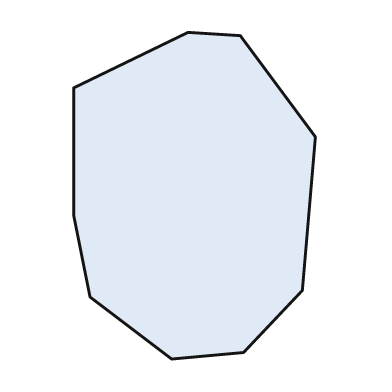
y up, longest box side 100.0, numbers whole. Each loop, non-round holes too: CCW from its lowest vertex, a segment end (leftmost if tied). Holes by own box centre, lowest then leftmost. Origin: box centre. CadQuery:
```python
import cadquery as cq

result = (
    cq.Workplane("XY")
    .moveTo(-7.0, -50.0)
    .lineTo(15.0, -48.0)
    .lineTo(33.0, -29.0)
    .lineTo(37.0, 18.0)
    .lineTo(14.0, 49.0)
    .lineTo(-2.0, 50.0)
    .lineTo(-37.0, 33.0)
    .lineTo(-37.0, -6.0)
    .lineTo(-32.0, -31.0)
    .close()
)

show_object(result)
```